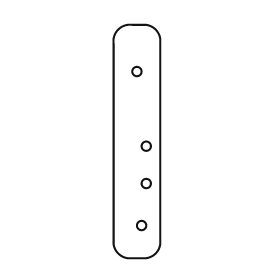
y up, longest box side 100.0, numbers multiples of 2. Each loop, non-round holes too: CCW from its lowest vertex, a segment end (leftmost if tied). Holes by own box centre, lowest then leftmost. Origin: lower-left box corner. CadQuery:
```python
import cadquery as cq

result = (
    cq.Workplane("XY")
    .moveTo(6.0, 0.0)
    .lineTo(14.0, 0.0)
    .threePointArc((18.0, 2.0), (20.0, 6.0))
    .lineTo(20.0, 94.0)
    .threePointArc((18.0, 98.0), (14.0, 100.0))
    .lineTo(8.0, 100.0)
    .threePointArc((2.0, 98.0), (0.0, 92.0))
    .lineTo(0.0, 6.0)
    .threePointArc((2.0, 2.0), (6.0, 0.0))
    .close()
    .moveTo(12.0, 14.0)
    .circle(2.0)
    .moveTo(14.0, 32.0)
    .circle(2.0)
    .moveTo(14.0, 48.0)
    .circle(2.0)
    .moveTo(10.0, 80.0)
    .circle(2.0)
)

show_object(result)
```